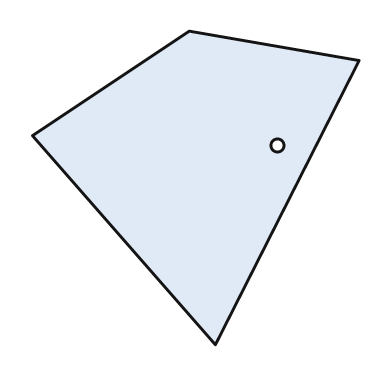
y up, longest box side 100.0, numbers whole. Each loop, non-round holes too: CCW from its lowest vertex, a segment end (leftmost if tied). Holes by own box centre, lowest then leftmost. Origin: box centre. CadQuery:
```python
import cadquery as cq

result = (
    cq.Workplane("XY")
    .moveTo(6.0, -48.0)
    .lineTo(50.0, 39.0)
    .lineTo(-2.0, 48.0)
    .lineTo(-50.0, 16.0)
    .close()
    .moveTo(25.0, 13.0)
    .circle(2.0)
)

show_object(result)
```